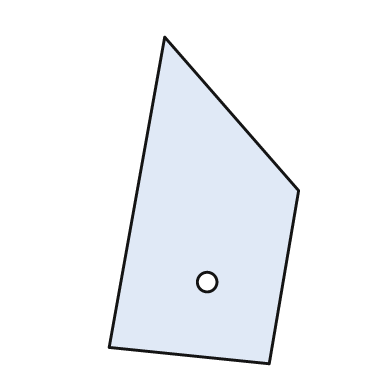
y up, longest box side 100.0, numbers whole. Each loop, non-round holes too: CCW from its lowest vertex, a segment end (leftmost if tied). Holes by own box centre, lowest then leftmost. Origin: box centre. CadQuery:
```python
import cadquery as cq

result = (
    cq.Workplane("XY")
    .moveTo(20.0, -50.0)
    .lineTo(29.0, 3.0)
    .lineTo(-12.0, 50.0)
    .lineTo(-29.0, -45.0)
    .close()
    .moveTo(1.0, -25.0)
    .circle(3.0)
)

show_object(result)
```